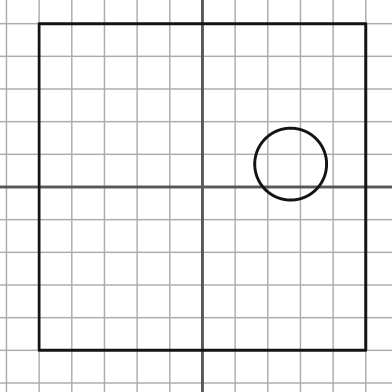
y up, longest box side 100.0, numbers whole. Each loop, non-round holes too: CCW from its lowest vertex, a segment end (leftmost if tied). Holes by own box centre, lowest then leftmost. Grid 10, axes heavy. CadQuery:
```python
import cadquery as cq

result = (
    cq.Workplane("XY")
    .moveTo(-50.0, -50.0)
    .lineTo(50.0, -50.0)
    .lineTo(50.0, 50.0)
    .lineTo(-50.0, 50.0)
    .close()
    .moveTo(27.0, 7.0)
    .circle(11.0)
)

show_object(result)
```